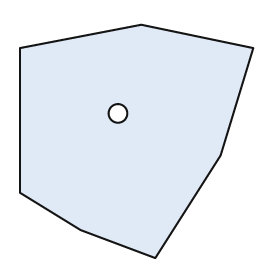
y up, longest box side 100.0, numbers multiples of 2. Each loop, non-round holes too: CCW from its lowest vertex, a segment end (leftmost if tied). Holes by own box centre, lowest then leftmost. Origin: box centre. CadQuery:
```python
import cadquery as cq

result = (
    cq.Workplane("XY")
    .moveTo(8.0, -50.0)
    .lineTo(36.0, -6.0)
    .lineTo(50.0, 40.0)
    .lineTo(2.0, 50.0)
    .lineTo(-50.0, 40.0)
    .lineTo(-50.0, -22.0)
    .lineTo(-24.0, -38.0)
    .close()
    .moveTo(-8.0, 12.0)
    .circle(4.0)
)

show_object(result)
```